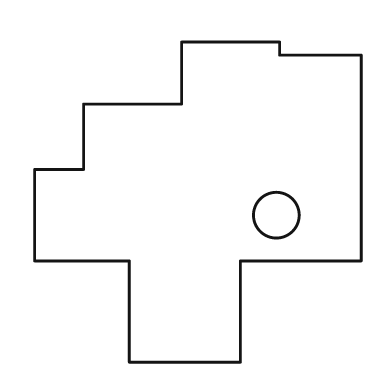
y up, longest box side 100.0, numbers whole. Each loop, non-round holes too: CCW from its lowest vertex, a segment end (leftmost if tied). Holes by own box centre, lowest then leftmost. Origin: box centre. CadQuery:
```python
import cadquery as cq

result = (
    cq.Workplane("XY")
    .moveTo(-21.0, -49.0)
    .lineTo(13.0, -49.0)
    .lineTo(13.0, -18.0)
    .lineTo(50.0, -18.0)
    .lineTo(50.0, 45.0)
    .lineTo(25.0, 45.0)
    .lineTo(25.0, 49.0)
    .lineTo(-5.0, 49.0)
    .lineTo(-5.0, 30.0)
    .lineTo(-35.0, 30.0)
    .lineTo(-35.0, 10.0)
    .lineTo(-50.0, 10.0)
    .lineTo(-50.0, -18.0)
    .lineTo(-21.0, -18.0)
    .close()
    .moveTo(24.0, -4.0)
    .circle(7.0)
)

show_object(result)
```